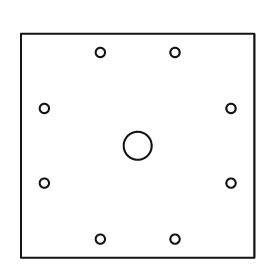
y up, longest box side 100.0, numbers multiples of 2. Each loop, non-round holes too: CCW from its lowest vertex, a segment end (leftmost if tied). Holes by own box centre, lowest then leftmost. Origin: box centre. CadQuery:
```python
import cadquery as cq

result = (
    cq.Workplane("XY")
    .moveTo(-50.0, -48.0)
    .lineTo(50.0, -48.0)
    .lineTo(50.0, 48.0)
    .lineTo(-50.0, 48.0)
    .close()
    .moveTo(-16.0, -40.0)
    .circle(2.0)
    .moveTo(16.0, -40.0)
    .circle(2.0)
    .moveTo(-40.0, -16.0)
    .circle(2.0)
    .moveTo(40.0, -16.0)
    .circle(2.0)
    .moveTo(0.0, 0.0)
    .circle(6.0)
    .moveTo(-40.0, 16.0)
    .circle(2.0)
    .moveTo(40.0, 16.0)
    .circle(2.0)
    .moveTo(-16.0, 40.0)
    .circle(2.0)
    .moveTo(16.0, 40.0)
    .circle(2.0)
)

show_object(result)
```